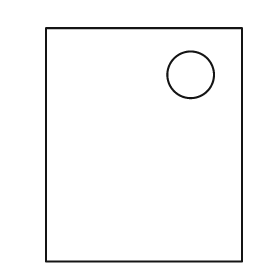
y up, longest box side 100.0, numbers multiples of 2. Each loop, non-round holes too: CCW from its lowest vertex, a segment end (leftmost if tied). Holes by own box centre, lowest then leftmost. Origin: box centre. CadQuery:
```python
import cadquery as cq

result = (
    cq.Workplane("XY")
    .moveTo(-42.0, -50.0)
    .lineTo(42.0, -50.0)
    .lineTo(42.0, 50.0)
    .lineTo(-42.0, 50.0)
    .close()
    .moveTo(20.0, 30.0)
    .circle(10.0)
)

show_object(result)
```